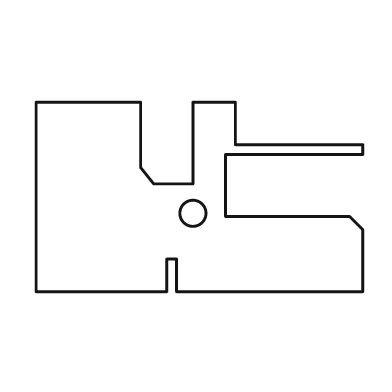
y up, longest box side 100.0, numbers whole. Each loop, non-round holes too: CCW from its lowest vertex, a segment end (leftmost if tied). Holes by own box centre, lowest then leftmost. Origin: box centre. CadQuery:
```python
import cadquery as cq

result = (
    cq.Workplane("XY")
    .moveTo(-50.0, -29.0)
    .lineTo(-10.0, -29.0)
    .lineTo(-10.0, -19.0)
    .lineTo(-7.0, -19.0)
    .lineTo(-7.0, -29.0)
    .lineTo(50.0, -29.0)
    .lineTo(50.0, -10.0)
    .lineTo(46.0, -6.0)
    .lineTo(8.0, -6.0)
    .lineTo(8.0, 13.0)
    .lineTo(50.0, 13.0)
    .lineTo(50.0, 16.0)
    .lineTo(11.0, 16.0)
    .lineTo(11.0, 29.0)
    .lineTo(-2.0, 29.0)
    .lineTo(-2.0, 4.0)
    .lineTo(-14.0, 4.0)
    .lineTo(-18.0, 9.0)
    .lineTo(-18.0, 29.0)
    .lineTo(-50.0, 29.0)
    .close()
    .moveTo(-2.0, -5.0)
    .circle(4.0)
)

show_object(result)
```